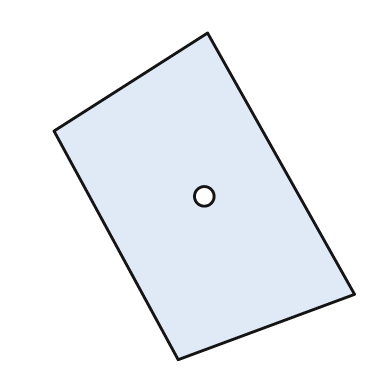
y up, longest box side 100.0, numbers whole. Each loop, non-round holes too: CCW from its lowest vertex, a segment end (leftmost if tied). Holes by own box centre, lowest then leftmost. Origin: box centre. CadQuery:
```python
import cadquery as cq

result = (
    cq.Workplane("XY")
    .moveTo(-8.0, -50.0)
    .lineTo(46.0, -30.0)
    .lineTo(1.0, 50.0)
    .lineTo(-46.0, 20.0)
    .close()
    .moveTo(0.0, 0.0)
    .circle(3.0)
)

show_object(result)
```